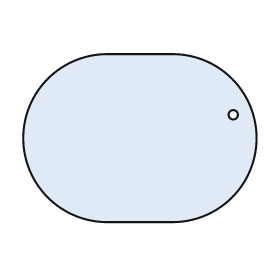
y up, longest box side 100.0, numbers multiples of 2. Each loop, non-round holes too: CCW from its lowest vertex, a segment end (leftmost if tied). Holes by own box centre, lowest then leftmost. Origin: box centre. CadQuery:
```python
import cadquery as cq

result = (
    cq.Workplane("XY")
    .moveTo(-14.0, -36.0)
    .lineTo(14.0, -36.0)
    .threePointArc((50.0, 0.0), (14.0, 36.0))
    .lineTo(-14.0, 36.0)
    .threePointArc((-50.0, 0.0), (-14.0, -36.0))
    .close()
    .moveTo(40.0, 10.0)
    .circle(2.0)
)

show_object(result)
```